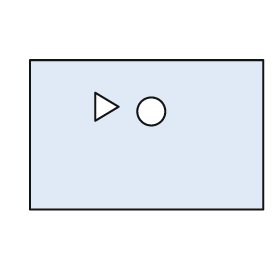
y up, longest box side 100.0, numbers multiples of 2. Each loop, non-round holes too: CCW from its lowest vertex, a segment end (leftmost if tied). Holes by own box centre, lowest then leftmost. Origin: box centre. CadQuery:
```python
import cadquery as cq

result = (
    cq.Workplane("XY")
    .moveTo(-50.0, -32.0)
    .lineTo(50.0, -32.0)
    .lineTo(50.0, 32.0)
    .lineTo(-50.0, 32.0)
    .close()
    .moveTo(2.0, 10.0)
    .circle(6.0)
    .moveTo(-22.0, 6.0)
    .lineTo(-12.0, 12.0)
    .lineTo(-22.0, 18.0)
    .close()
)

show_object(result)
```